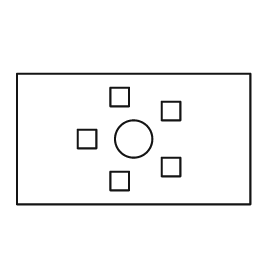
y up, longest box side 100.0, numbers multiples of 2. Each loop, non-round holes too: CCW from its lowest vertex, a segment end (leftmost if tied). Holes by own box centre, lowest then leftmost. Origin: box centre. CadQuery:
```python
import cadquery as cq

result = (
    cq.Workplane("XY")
    .moveTo(-50.0, -28.0)
    .lineTo(50.0, -28.0)
    .lineTo(50.0, 28.0)
    .lineTo(-50.0, 28.0)
    .close()
    .moveTo(-10.0, -22.0)
    .lineTo(-2.0, -22.0)
    .lineTo(-2.0, -14.0)
    .lineTo(-10.0, -14.0)
    .close()
    .moveTo(12.0, -16.0)
    .lineTo(20.0, -16.0)
    .lineTo(20.0, -8.0)
    .lineTo(12.0, -8.0)
    .close()
    .moveTo(-24.0, -4.0)
    .lineTo(-16.0, -4.0)
    .lineTo(-16.0, 4.0)
    .lineTo(-24.0, 4.0)
    .close()
    .moveTo(0.0, 0.0)
    .circle(8.0)
    .moveTo(12.0, 8.0)
    .lineTo(20.0, 8.0)
    .lineTo(20.0, 16.0)
    .lineTo(12.0, 16.0)
    .close()
    .moveTo(-10.0, 14.0)
    .lineTo(-2.0, 14.0)
    .lineTo(-2.0, 22.0)
    .lineTo(-10.0, 22.0)
    .close()
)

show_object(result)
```